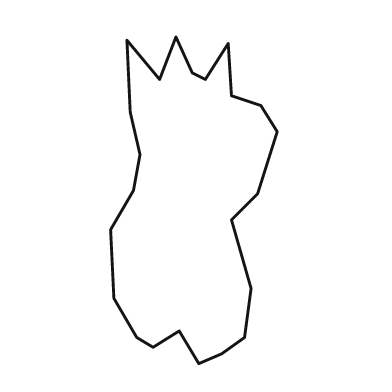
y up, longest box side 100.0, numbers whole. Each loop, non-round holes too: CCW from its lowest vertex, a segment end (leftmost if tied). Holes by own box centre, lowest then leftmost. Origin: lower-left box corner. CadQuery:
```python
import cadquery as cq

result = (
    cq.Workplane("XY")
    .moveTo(27.0, 0.0)
    .lineTo(34.0, 3.0)
    .lineTo(41.0, 8.0)
    .lineTo(43.0, 23.0)
    .lineTo(37.0, 44.0)
    .lineTo(45.0, 52.0)
    .lineTo(51.0, 71.0)
    .lineTo(46.0, 79.0)
    .lineTo(37.0, 82.0)
    .lineTo(36.0, 98.0)
    .lineTo(29.0, 87.0)
    .lineTo(25.0, 89.0)
    .lineTo(20.0, 100.0)
    .lineTo(15.0, 87.0)
    .lineTo(5.0, 99.0)
    .lineTo(6.0, 77.0)
    .lineTo(9.0, 64.0)
    .lineTo(7.0, 53.0)
    .lineTo(0.0, 41.0)
    .lineTo(1.0, 20.0)
    .lineTo(8.0, 8.0)
    .lineTo(13.0, 5.0)
    .lineTo(21.0, 10.0)
    .close()
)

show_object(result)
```